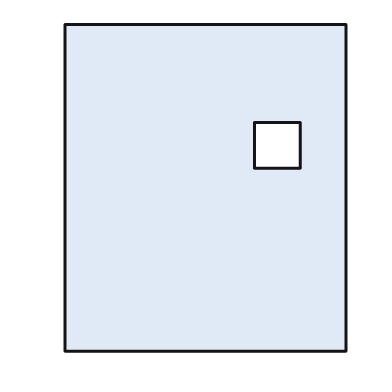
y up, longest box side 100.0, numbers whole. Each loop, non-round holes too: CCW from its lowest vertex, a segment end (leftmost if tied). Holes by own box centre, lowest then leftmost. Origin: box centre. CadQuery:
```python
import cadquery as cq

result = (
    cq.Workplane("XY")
    .moveTo(-43.0, -50.0)
    .lineTo(43.0, -50.0)
    .lineTo(43.0, 50.0)
    .lineTo(-43.0, 50.0)
    .close()
    .moveTo(15.0, 6.0)
    .lineTo(29.0, 6.0)
    .lineTo(29.0, 20.0)
    .lineTo(15.0, 20.0)
    .close()
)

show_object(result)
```